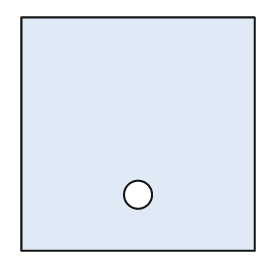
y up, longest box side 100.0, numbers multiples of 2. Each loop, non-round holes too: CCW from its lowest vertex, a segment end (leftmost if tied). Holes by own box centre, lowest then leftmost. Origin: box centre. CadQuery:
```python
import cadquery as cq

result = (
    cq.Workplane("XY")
    .moveTo(-50.0, -50.0)
    .lineTo(50.0, -50.0)
    .lineTo(50.0, 50.0)
    .lineTo(-50.0, 50.0)
    .close()
    .moveTo(0.0, -26.0)
    .circle(6.0)
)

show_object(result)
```